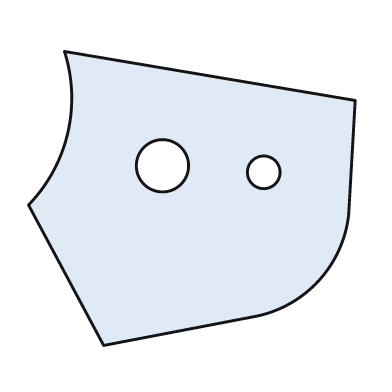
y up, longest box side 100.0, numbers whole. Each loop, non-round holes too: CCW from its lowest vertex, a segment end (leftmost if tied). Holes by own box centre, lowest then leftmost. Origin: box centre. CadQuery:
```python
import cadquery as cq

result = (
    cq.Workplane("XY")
    .moveTo(-27.0, -45.0)
    .lineTo(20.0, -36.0)
    .threePointArc((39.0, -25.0), (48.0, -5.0))
    .lineTo(50.0, 30.0)
    .lineTo(-39.0, 45.0)
    .threePointArc((-38.0, 20.0), (-50.0, -2.0))
    .close()
    .moveTo(22.0, 8.0)
    .circle(5.0)
    .moveTo(-9.0, 10.0)
    .circle(8.0)
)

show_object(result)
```